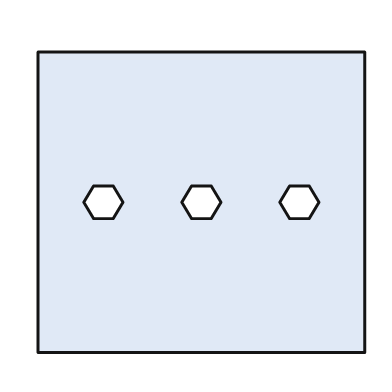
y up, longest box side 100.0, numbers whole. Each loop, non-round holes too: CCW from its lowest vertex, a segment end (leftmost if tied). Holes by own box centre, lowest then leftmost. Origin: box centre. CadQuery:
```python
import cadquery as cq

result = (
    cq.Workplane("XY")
    .moveTo(-50.0, -46.0)
    .lineTo(50.0, -46.0)
    .lineTo(50.0, 46.0)
    .lineTo(-50.0, 46.0)
    .close()
    .moveTo(-33.0, -5.0)
    .lineTo(-27.0, -5.0)
    .lineTo(-24.0, 0.0)
    .lineTo(-27.0, 5.0)
    .lineTo(-33.0, 5.0)
    .lineTo(-36.0, 0.0)
    .close()
    .moveTo(-3.0, -5.0)
    .lineTo(3.0, -5.0)
    .lineTo(6.0, 0.0)
    .lineTo(3.0, 5.0)
    .lineTo(-3.0, 5.0)
    .lineTo(-6.0, 0.0)
    .close()
    .moveTo(27.0, -5.0)
    .lineTo(33.0, -5.0)
    .lineTo(36.0, 0.0)
    .lineTo(33.0, 5.0)
    .lineTo(27.0, 5.0)
    .lineTo(24.0, 0.0)
    .close()
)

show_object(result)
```